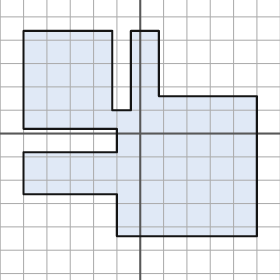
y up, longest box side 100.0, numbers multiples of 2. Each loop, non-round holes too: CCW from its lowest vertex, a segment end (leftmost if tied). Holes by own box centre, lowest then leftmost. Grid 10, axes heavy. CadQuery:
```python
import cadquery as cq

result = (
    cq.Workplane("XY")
    .moveTo(-10.0, -44.0)
    .lineTo(50.0, -44.0)
    .lineTo(50.0, 16.0)
    .lineTo(8.0, 16.0)
    .lineTo(8.0, 44.0)
    .lineTo(-4.0, 44.0)
    .lineTo(-4.0, 10.0)
    .lineTo(-12.0, 10.0)
    .lineTo(-12.0, 44.0)
    .lineTo(-50.0, 44.0)
    .lineTo(-50.0, 2.0)
    .lineTo(-10.0, 2.0)
    .lineTo(-10.0, -8.0)
    .lineTo(-50.0, -8.0)
    .lineTo(-50.0, -26.0)
    .lineTo(-10.0, -26.0)
    .close()
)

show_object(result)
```